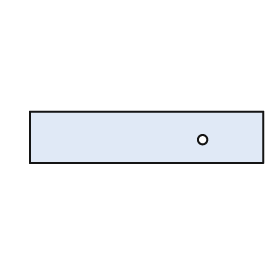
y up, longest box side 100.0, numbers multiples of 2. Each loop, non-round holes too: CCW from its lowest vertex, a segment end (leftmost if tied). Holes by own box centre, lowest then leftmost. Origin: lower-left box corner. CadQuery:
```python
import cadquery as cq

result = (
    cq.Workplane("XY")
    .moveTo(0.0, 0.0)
    .lineTo(100.0, 0.0)
    .lineTo(100.0, 22.0)
    .lineTo(0.0, 22.0)
    .close()
    .moveTo(74.0, 10.0)
    .circle(2.0)
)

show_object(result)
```